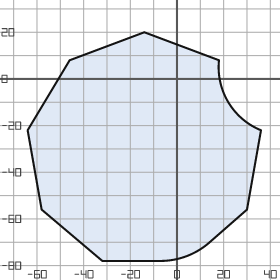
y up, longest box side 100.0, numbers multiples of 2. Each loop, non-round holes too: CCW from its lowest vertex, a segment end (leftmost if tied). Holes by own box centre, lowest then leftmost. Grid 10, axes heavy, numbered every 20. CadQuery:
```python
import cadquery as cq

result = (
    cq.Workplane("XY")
    .moveTo(-32.0, -78.0)
    .lineTo(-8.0, -78.0)
    .threePointArc((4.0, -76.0), (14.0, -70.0))
    .lineTo(30.0, -56.0)
    .lineTo(36.0, -22.0)
    .threePointArc((22.0, -10.0), (18.0, 8.0))
    .lineTo(-14.0, 20.0)
    .lineTo(-46.0, 8.0)
    .lineTo(-64.0, -22.0)
    .lineTo(-58.0, -56.0)
    .close()
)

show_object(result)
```